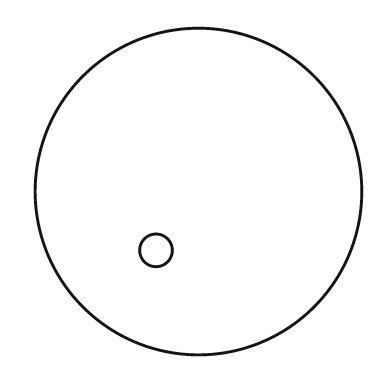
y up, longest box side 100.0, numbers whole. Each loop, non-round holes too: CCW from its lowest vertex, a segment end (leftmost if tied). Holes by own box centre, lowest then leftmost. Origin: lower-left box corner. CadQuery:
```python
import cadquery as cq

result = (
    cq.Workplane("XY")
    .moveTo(50.0, 50.0)
    .circle(50.0)
    .moveTo(37.0, 32.0)
    .circle(5.0)
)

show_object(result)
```